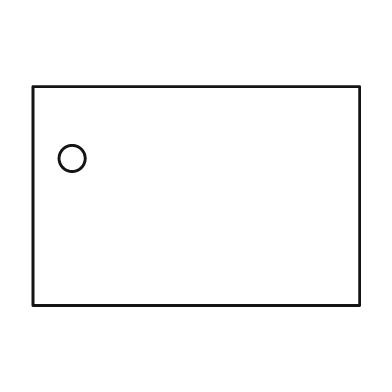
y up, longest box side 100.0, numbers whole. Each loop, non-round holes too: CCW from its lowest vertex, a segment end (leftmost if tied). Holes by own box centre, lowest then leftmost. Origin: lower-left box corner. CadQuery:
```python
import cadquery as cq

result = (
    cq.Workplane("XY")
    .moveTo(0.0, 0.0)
    .lineTo(100.0, 0.0)
    .lineTo(100.0, 67.0)
    .lineTo(0.0, 67.0)
    .close()
    .moveTo(12.0, 45.0)
    .circle(4.0)
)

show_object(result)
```